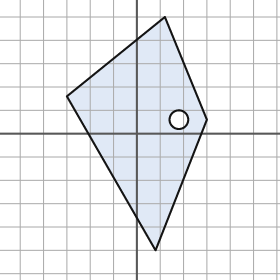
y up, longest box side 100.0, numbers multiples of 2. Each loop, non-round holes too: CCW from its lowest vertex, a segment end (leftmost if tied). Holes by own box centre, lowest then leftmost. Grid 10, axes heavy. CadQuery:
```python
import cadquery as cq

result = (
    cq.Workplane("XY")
    .moveTo(8.0, -50.0)
    .lineTo(30.0, 6.0)
    .lineTo(12.0, 50.0)
    .lineTo(-30.0, 16.0)
    .close()
    .moveTo(18.0, 6.0)
    .circle(4.0)
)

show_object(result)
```